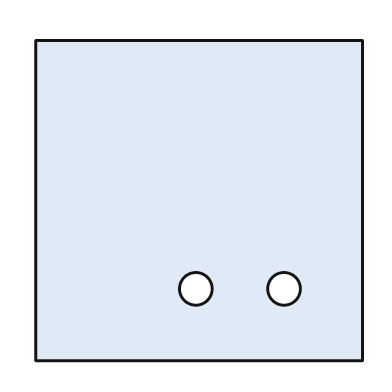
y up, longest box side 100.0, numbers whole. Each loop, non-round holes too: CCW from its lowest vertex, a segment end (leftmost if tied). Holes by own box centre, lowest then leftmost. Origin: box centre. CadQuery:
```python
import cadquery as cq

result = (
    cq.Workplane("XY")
    .moveTo(-50.0, -49.0)
    .lineTo(50.0, -49.0)
    .lineTo(50.0, 49.0)
    .lineTo(-50.0, 49.0)
    .close()
    .moveTo(-1.0, -27.0)
    .circle(5.0)
    .moveTo(26.0, -27.0)
    .circle(5.0)
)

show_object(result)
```